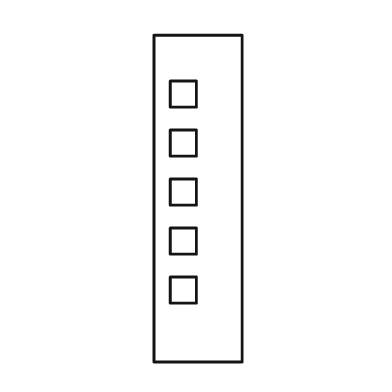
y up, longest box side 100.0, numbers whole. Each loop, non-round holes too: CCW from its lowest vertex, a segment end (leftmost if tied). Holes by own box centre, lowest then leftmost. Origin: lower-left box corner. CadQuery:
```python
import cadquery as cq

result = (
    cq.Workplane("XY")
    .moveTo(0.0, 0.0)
    .lineTo(27.0, 0.0)
    .lineTo(27.0, 100.0)
    .lineTo(0.0, 100.0)
    .close()
    .moveTo(5.0, 18.0)
    .lineTo(13.0, 18.0)
    .lineTo(13.0, 26.0)
    .lineTo(5.0, 26.0)
    .close()
    .moveTo(5.0, 33.0)
    .lineTo(13.0, 33.0)
    .lineTo(13.0, 41.0)
    .lineTo(5.0, 41.0)
    .close()
    .moveTo(5.0, 48.0)
    .lineTo(13.0, 48.0)
    .lineTo(13.0, 56.0)
    .lineTo(5.0, 56.0)
    .close()
    .moveTo(5.0, 63.0)
    .lineTo(13.0, 63.0)
    .lineTo(13.0, 71.0)
    .lineTo(5.0, 71.0)
    .close()
    .moveTo(5.0, 78.0)
    .lineTo(13.0, 78.0)
    .lineTo(13.0, 86.0)
    .lineTo(5.0, 86.0)
    .close()
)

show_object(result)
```